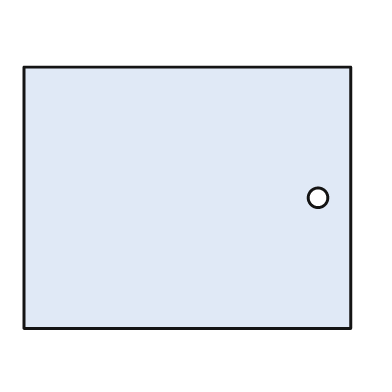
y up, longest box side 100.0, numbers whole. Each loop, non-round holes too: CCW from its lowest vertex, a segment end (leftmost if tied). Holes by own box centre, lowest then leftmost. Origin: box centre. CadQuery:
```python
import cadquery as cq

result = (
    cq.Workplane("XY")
    .moveTo(-50.0, -40.0)
    .lineTo(50.0, -40.0)
    .lineTo(50.0, 40.0)
    .lineTo(-50.0, 40.0)
    .close()
    .moveTo(40.0, 0.0)
    .circle(3.0)
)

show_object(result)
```